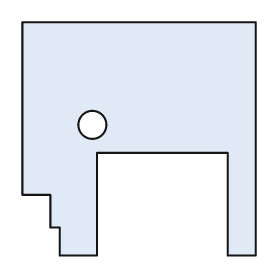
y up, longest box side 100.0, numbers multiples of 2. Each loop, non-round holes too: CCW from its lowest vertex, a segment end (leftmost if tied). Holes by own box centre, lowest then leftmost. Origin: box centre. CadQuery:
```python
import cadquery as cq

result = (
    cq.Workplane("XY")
    .moveTo(-34.0, -50.0)
    .lineTo(-18.0, -50.0)
    .lineTo(-18.0, -6.0)
    .lineTo(38.0, -6.0)
    .lineTo(38.0, -50.0)
    .lineTo(50.0, -50.0)
    .lineTo(50.0, 50.0)
    .lineTo(-50.0, 50.0)
    .lineTo(-50.0, -24.0)
    .lineTo(-38.0, -24.0)
    .lineTo(-38.0, -38.0)
    .lineTo(-34.0, -38.0)
    .close()
    .moveTo(-20.0, 6.0)
    .circle(6.0)
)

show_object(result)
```